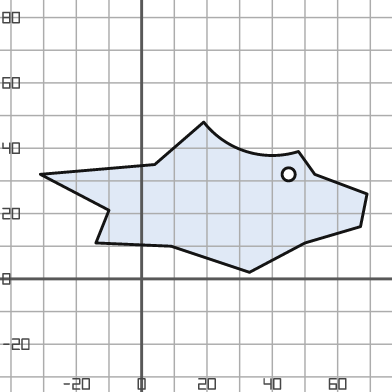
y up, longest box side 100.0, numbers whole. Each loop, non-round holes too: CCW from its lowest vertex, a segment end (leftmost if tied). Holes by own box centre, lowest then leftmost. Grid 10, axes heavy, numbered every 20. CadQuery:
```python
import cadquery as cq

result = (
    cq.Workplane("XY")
    .moveTo(33.0, 2.0)
    .lineTo(50.0, 11.0)
    .lineTo(67.0, 16.0)
    .lineTo(69.0, 26.0)
    .lineTo(53.0, 32.0)
    .lineTo(48.0, 39.0)
    .threePointArc((32.0, 39.0), (19.0, 48.0))
    .lineTo(4.0, 35.0)
    .lineTo(-31.0, 32.0)
    .lineTo(-10.0, 21.0)
    .lineTo(-14.0, 11.0)
    .lineTo(9.0, 10.0)
    .close()
    .moveTo(45.0, 32.0)
    .circle(2.0)
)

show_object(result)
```